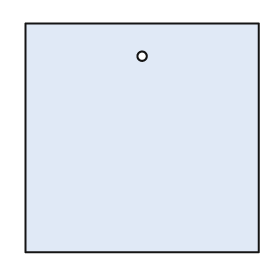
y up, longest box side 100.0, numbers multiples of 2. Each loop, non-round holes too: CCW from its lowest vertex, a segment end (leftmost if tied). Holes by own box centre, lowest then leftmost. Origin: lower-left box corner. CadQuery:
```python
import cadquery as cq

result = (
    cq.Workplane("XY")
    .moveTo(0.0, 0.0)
    .lineTo(100.0, 0.0)
    .lineTo(100.0, 98.0)
    .lineTo(0.0, 98.0)
    .close()
    .moveTo(50.0, 84.0)
    .circle(2.0)
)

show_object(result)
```